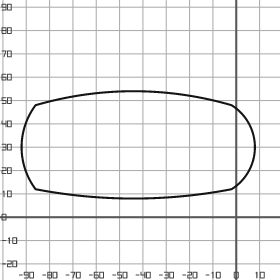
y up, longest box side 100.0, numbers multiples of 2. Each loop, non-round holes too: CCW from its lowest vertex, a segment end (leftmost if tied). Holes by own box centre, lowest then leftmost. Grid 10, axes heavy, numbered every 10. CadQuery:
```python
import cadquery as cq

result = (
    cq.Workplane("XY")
    .moveTo(-86.0, 12.0)
    .threePointArc((-44.0, 8.0), (-2.0, 12.0))
    .threePointArc((8.0, 30.0), (-2.0, 48.0))
    .threePointArc((-44.0, 54.0), (-86.0, 48.0))
    .threePointArc((-92.0, 30.0), (-86.0, 12.0))
    .close()
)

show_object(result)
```